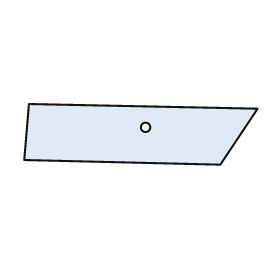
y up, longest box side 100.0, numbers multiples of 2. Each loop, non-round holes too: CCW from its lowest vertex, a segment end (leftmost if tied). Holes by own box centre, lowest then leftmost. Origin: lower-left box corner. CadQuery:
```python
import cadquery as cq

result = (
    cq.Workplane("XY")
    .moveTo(84.0, 0.0)
    .lineTo(100.0, 24.0)
    .lineTo(2.0, 26.0)
    .lineTo(0.0, 2.0)
    .close()
    .moveTo(52.0, 16.0)
    .circle(2.0)
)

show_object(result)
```